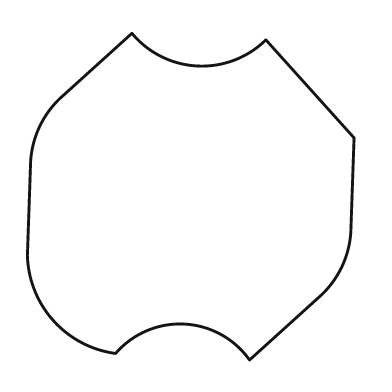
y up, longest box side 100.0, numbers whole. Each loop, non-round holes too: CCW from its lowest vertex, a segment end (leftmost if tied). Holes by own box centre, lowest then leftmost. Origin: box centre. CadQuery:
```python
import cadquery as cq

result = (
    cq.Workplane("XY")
    .moveTo(18.0, -50.0)
    .lineTo(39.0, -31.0)
    .threePointArc((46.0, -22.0), (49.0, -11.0))
    .lineTo(50.0, 18.0)
    .lineTo(23.0, 48.0)
    .threePointArc((2.0, 40.0), (-18.0, 50.0))
    .lineTo(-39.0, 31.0)
    .threePointArc((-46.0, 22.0), (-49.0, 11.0))
    .lineTo(-50.0, -18.0)
    .threePointArc((-42.0, -38.0), (-23.0, -48.0))
    .threePointArc((-2.0, -39.0), (18.0, -50.0))
    .close()
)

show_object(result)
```